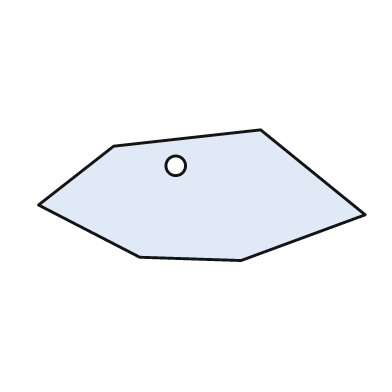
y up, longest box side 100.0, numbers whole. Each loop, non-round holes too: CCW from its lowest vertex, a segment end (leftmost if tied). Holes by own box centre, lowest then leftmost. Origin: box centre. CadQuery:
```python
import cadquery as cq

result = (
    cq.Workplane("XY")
    .moveTo(12.0, -20.0)
    .lineTo(50.0, -6.0)
    .lineTo(18.0, 20.0)
    .lineTo(-27.0, 15.0)
    .lineTo(-50.0, -3.0)
    .lineTo(-19.0, -19.0)
    .close()
    .moveTo(-8.0, 9.0)
    .circle(3.0)
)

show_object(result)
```